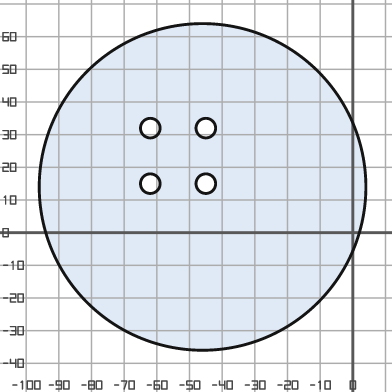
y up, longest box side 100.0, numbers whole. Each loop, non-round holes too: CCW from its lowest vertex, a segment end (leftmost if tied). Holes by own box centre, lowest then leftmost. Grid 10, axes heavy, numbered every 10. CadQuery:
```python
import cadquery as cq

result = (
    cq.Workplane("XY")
    .moveTo(-46.0, 14.0)
    .circle(50.0)
    .moveTo(-62.0, 15.0)
    .circle(3.0)
    .moveTo(-45.0, 15.0)
    .circle(3.0)
    .moveTo(-62.0, 32.0)
    .circle(3.0)
    .moveTo(-45.0, 32.0)
    .circle(3.0)
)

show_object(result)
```